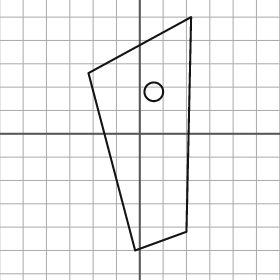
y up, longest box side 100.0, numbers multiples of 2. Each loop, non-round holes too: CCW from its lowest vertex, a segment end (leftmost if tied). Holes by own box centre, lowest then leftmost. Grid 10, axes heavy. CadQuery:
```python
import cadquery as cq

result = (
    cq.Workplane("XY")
    .moveTo(-2.0, -50.0)
    .lineTo(20.0, -42.0)
    .lineTo(22.0, 50.0)
    .lineTo(-22.0, 26.0)
    .close()
    .moveTo(6.0, 18.0)
    .circle(4.0)
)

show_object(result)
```